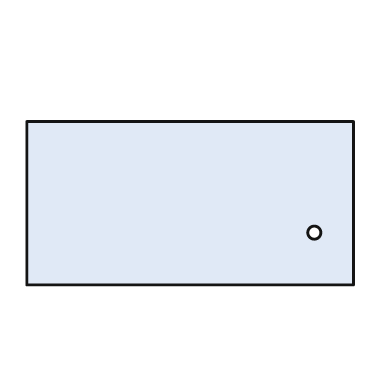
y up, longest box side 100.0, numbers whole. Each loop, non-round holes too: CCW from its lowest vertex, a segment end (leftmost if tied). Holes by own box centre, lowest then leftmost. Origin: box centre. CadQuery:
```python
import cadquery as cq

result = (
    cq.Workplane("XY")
    .moveTo(-50.0, -25.0)
    .lineTo(50.0, -25.0)
    .lineTo(50.0, 25.0)
    .lineTo(-50.0, 25.0)
    .close()
    .moveTo(38.0, -9.0)
    .circle(2.0)
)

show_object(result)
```